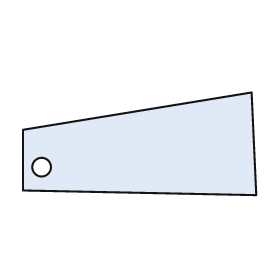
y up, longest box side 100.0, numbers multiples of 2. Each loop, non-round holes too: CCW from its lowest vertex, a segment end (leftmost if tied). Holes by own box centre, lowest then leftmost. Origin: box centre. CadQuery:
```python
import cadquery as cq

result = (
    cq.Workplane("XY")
    .moveTo(50.0, -22.0)
    .lineTo(48.0, 22.0)
    .lineTo(-50.0, 6.0)
    .lineTo(-50.0, -20.0)
    .close()
    .moveTo(-42.0, -10.0)
    .circle(4.0)
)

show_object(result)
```